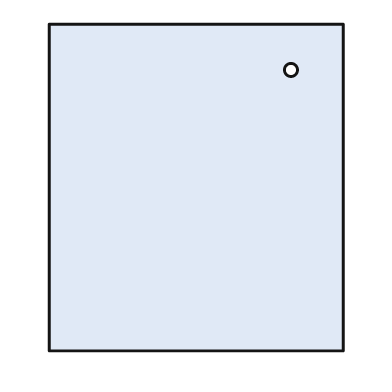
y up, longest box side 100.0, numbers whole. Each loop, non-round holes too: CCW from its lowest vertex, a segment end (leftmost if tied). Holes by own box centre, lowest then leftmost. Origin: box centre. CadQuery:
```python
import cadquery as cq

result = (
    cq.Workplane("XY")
    .moveTo(-45.0, -50.0)
    .lineTo(45.0, -50.0)
    .lineTo(45.0, 50.0)
    .lineTo(-45.0, 50.0)
    .close()
    .moveTo(29.0, 36.0)
    .circle(2.0)
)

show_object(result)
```